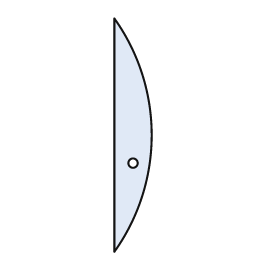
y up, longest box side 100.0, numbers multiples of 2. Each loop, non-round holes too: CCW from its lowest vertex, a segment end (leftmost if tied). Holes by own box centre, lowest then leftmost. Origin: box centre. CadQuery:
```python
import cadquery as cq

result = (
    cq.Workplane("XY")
    .moveTo(-8.0, -50.0)
    .threePointArc((8.0, 0.0), (-8.0, 50.0))
    .close()
    .moveTo(0.0, -12.0)
    .circle(2.0)
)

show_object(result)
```